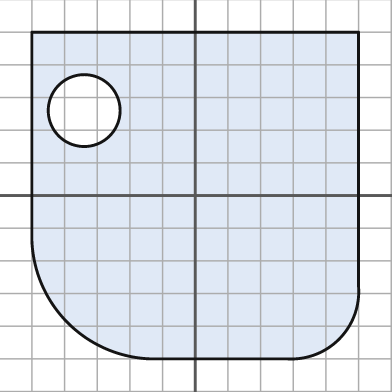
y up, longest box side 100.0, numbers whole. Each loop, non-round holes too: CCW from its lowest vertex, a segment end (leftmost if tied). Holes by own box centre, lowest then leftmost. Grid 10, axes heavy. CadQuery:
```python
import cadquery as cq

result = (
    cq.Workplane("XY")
    .moveTo(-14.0, -50.0)
    .lineTo(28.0, -50.0)
    .threePointArc((44.0, -44.0), (50.0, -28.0))
    .lineTo(50.0, 50.0)
    .lineTo(-50.0, 50.0)
    .lineTo(-50.0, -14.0)
    .threePointArc((-39.0, -39.0), (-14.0, -50.0))
    .close()
    .moveTo(-34.0, 26.0)
    .circle(11.0)
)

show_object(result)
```